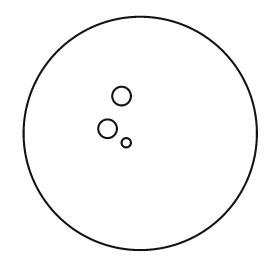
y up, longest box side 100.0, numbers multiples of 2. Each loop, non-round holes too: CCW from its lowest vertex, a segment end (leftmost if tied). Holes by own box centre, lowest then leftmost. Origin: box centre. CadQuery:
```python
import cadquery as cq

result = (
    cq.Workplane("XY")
    .moveTo(0.0, 0.0)
    .circle(50.0)
    .moveTo(-6.0, -4.0)
    .circle(2.0)
    .moveTo(-14.0, 2.0)
    .circle(4.0)
    .moveTo(-8.0, 16.0)
    .circle(4.0)
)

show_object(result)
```